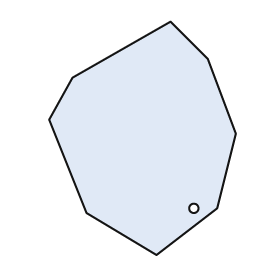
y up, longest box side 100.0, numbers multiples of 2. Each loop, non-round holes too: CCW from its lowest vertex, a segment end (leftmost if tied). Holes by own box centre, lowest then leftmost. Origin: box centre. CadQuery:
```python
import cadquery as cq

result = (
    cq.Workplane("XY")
    .moveTo(6.0, -50.0)
    .lineTo(32.0, -30.0)
    .lineTo(40.0, 2.0)
    .lineTo(28.0, 34.0)
    .lineTo(12.0, 50.0)
    .lineTo(-30.0, 26.0)
    .lineTo(-40.0, 8.0)
    .lineTo(-24.0, -32.0)
    .close()
    .moveTo(22.0, -30.0)
    .circle(2.0)
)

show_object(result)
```